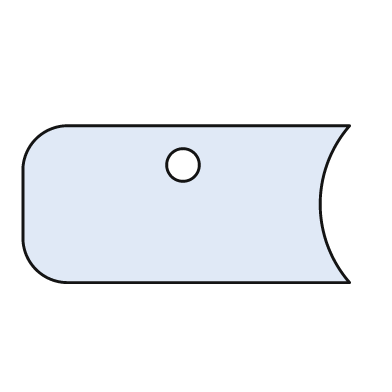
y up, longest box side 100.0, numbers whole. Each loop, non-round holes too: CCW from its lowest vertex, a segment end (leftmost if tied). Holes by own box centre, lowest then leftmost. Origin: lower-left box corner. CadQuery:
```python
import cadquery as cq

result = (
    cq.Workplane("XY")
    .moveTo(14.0, 0.0)
    .lineTo(100.0, 0.0)
    .threePointArc((91.0, 24.0), (100.0, 48.0))
    .lineTo(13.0, 48.0)
    .threePointArc((4.0, 44.0), (0.0, 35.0))
    .lineTo(0.0, 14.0)
    .threePointArc((4.0, 4.0), (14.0, 0.0))
    .close()
    .moveTo(49.0, 36.0)
    .circle(5.0)
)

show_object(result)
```